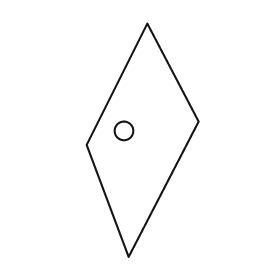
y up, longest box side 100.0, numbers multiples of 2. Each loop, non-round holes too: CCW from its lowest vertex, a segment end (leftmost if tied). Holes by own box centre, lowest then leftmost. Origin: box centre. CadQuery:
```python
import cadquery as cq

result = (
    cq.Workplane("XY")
    .moveTo(-6.0, -50.0)
    .lineTo(24.0, 8.0)
    .lineTo(2.0, 50.0)
    .lineTo(-24.0, -2.0)
    .close()
    .moveTo(-8.0, 4.0)
    .circle(4.0)
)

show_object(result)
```